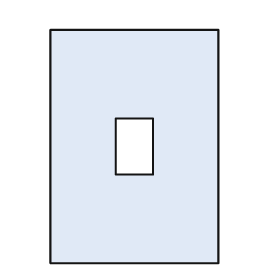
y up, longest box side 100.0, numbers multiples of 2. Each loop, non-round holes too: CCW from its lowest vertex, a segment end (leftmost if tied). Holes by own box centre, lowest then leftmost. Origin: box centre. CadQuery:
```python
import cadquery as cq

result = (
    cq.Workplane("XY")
    .moveTo(-36.0, -50.0)
    .lineTo(36.0, -50.0)
    .lineTo(36.0, 50.0)
    .lineTo(-36.0, 50.0)
    .close()
    .moveTo(-8.0, -12.0)
    .lineTo(8.0, -12.0)
    .lineTo(8.0, 12.0)
    .lineTo(-8.0, 12.0)
    .close()
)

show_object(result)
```